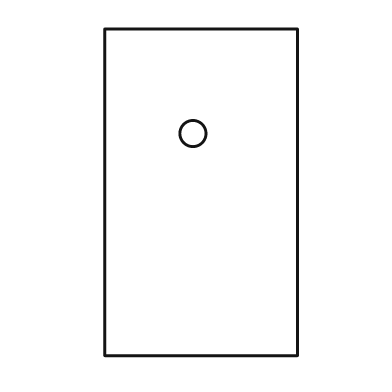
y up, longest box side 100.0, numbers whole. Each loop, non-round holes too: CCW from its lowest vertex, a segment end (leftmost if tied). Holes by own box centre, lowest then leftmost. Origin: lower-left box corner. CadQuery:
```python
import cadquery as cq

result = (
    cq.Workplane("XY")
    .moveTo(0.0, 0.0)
    .lineTo(59.0, 0.0)
    .lineTo(59.0, 100.0)
    .lineTo(0.0, 100.0)
    .close()
    .moveTo(27.0, 68.0)
    .circle(4.0)
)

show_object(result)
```